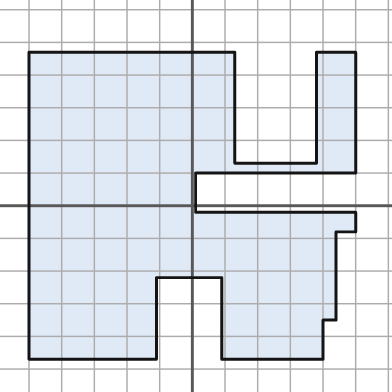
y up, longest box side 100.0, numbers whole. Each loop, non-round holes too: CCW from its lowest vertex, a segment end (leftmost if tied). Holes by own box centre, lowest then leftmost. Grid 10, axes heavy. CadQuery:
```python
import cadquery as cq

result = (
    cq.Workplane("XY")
    .moveTo(-50.0, -47.0)
    .lineTo(-11.0, -47.0)
    .lineTo(-11.0, -22.0)
    .lineTo(9.0, -22.0)
    .lineTo(9.0, -47.0)
    .lineTo(40.0, -47.0)
    .lineTo(40.0, -35.0)
    .lineTo(44.0, -35.0)
    .lineTo(44.0, -8.0)
    .lineTo(50.0, -8.0)
    .lineTo(50.0, -2.0)
    .lineTo(1.0, -2.0)
    .lineTo(1.0, 10.0)
    .lineTo(50.0, 10.0)
    .lineTo(50.0, 47.0)
    .lineTo(38.0, 47.0)
    .lineTo(38.0, 13.0)
    .lineTo(13.0, 13.0)
    .lineTo(13.0, 47.0)
    .lineTo(-50.0, 47.0)
    .close()
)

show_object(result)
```